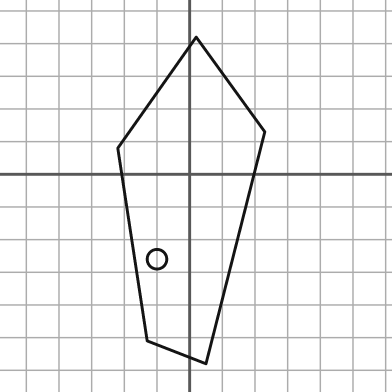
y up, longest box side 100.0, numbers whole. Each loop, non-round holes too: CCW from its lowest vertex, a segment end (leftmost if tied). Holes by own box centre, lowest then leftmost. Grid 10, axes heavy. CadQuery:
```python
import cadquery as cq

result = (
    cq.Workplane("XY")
    .moveTo(5.0, -58.0)
    .lineTo(23.0, 13.0)
    .lineTo(2.0, 42.0)
    .lineTo(-22.0, 8.0)
    .lineTo(-13.0, -51.0)
    .close()
    .moveTo(-10.0, -26.0)
    .circle(3.0)
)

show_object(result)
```